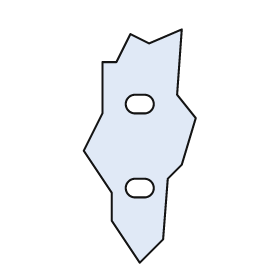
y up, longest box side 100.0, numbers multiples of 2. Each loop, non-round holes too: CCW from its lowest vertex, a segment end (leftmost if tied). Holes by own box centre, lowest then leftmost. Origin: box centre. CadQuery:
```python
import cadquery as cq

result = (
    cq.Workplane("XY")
    .moveTo(0.0, -50.0)
    .lineTo(10.0, -40.0)
    .lineTo(12.0, -14.0)
    .lineTo(18.0, -8.0)
    .lineTo(24.0, 12.0)
    .lineTo(16.0, 22.0)
    .lineTo(18.0, 50.0)
    .lineTo(4.0, 44.0)
    .lineTo(-4.0, 48.0)
    .lineTo(-10.0, 36.0)
    .lineTo(-16.0, 36.0)
    .lineTo(-16.0, 14.0)
    .lineTo(-24.0, -2.0)
    .lineTo(-12.0, -20.0)
    .lineTo(-12.0, -32.0)
    .close()
    .moveTo(-2.0, -22.0)
    .lineTo(2.0, -22.0)
    .threePointArc((6.0, -18.0), (2.0, -14.0))
    .lineTo(-2.0, -14.0)
    .threePointArc((-6.0, -18.0), (-2.0, -22.0))
    .close()
    .moveTo(-2.0, 14.0)
    .lineTo(2.0, 14.0)
    .threePointArc((6.0, 18.0), (2.0, 22.0))
    .lineTo(-2.0, 22.0)
    .threePointArc((-6.0, 18.0), (-2.0, 14.0))
    .close()
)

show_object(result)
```